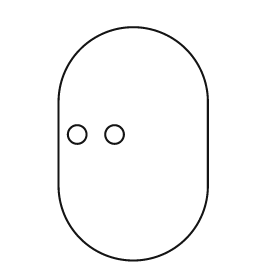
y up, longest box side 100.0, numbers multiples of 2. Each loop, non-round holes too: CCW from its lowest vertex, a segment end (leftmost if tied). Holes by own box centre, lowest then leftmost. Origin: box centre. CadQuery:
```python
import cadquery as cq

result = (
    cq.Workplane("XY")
    .moveTo(-32.0, -18.0)
    .threePointArc((0.0, -50.0), (32.0, -18.0))
    .lineTo(32.0, 18.0)
    .threePointArc((0.0, 50.0), (-32.0, 18.0))
    .close()
    .moveTo(-24.0, 4.0)
    .circle(4.0)
    .moveTo(-8.0, 4.0)
    .circle(4.0)
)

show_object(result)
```